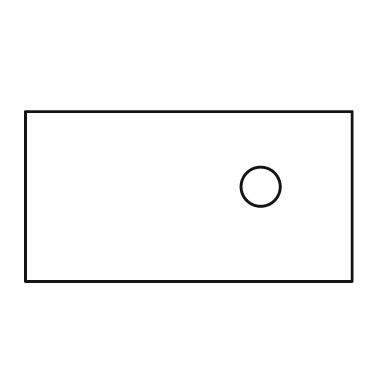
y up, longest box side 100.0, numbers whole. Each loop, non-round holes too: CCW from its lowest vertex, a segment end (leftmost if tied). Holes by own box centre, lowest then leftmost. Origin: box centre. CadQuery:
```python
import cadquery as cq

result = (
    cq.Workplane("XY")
    .moveTo(-50.0, -26.0)
    .lineTo(50.0, -26.0)
    .lineTo(50.0, 26.0)
    .lineTo(-50.0, 26.0)
    .close()
    .moveTo(22.0, 3.0)
    .circle(6.0)
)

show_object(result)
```